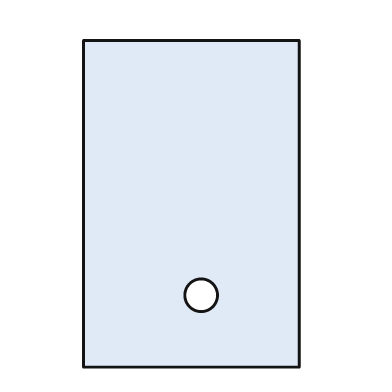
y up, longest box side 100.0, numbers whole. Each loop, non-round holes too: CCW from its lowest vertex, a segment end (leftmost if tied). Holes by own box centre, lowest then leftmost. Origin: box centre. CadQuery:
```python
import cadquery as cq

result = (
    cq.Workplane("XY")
    .moveTo(-33.0, -50.0)
    .lineTo(33.0, -50.0)
    .lineTo(33.0, 50.0)
    .lineTo(-33.0, 50.0)
    .close()
    .moveTo(3.0, -28.0)
    .circle(5.0)
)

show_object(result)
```